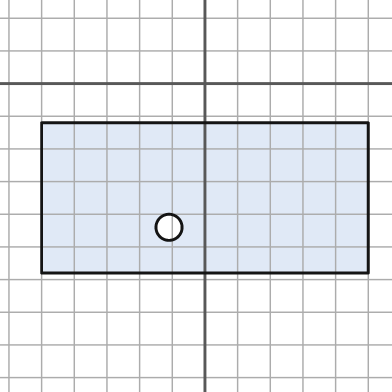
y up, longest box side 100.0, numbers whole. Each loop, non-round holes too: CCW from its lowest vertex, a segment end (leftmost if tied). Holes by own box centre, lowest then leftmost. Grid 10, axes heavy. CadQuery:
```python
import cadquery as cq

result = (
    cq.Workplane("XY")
    .moveTo(-50.0, -58.0)
    .lineTo(50.0, -58.0)
    .lineTo(50.0, -12.0)
    .lineTo(-50.0, -12.0)
    .close()
    .moveTo(-11.0, -44.0)
    .circle(4.0)
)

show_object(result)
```